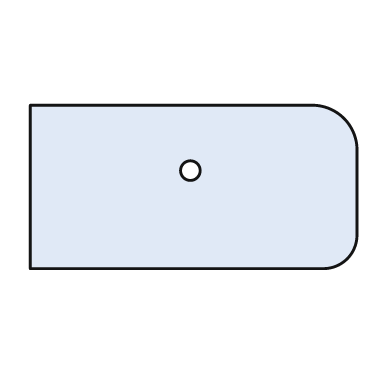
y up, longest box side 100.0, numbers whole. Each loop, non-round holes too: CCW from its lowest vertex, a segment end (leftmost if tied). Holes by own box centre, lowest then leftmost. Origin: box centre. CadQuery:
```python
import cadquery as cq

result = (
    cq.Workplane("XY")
    .moveTo(-50.0, -25.0)
    .lineTo(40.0, -25.0)
    .threePointArc((47.0, -22.0), (50.0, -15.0))
    .lineTo(50.0, 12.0)
    .threePointArc((46.0, 21.0), (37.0, 25.0))
    .lineTo(-50.0, 25.0)
    .close()
    .moveTo(-1.0, 5.0)
    .circle(3.0)
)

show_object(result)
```